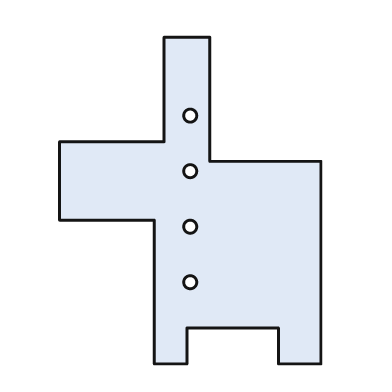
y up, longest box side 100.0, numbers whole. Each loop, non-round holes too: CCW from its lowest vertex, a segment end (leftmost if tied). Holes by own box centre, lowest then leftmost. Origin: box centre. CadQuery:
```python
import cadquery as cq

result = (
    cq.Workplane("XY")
    .moveTo(-11.0, -50.0)
    .lineTo(-1.0, -50.0)
    .lineTo(-1.0, -39.0)
    .lineTo(27.0, -39.0)
    .lineTo(27.0, -50.0)
    .lineTo(40.0, -50.0)
    .lineTo(40.0, 12.0)
    .lineTo(6.0, 12.0)
    .lineTo(6.0, 50.0)
    .lineTo(-8.0, 50.0)
    .lineTo(-8.0, 18.0)
    .lineTo(-40.0, 18.0)
    .lineTo(-40.0, -6.0)
    .lineTo(-11.0, -6.0)
    .close()
    .moveTo(0.0, -25.0)
    .circle(2.0)
    .moveTo(0.0, -8.0)
    .circle(2.0)
    .moveTo(0.0, 9.0)
    .circle(2.0)
    .moveTo(0.0, 26.0)
    .circle(2.0)
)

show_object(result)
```